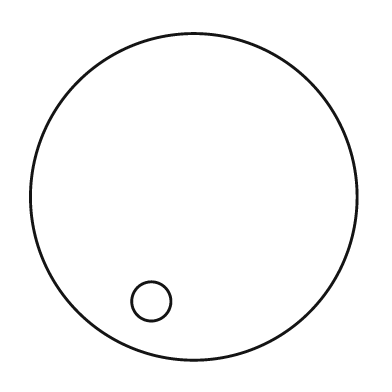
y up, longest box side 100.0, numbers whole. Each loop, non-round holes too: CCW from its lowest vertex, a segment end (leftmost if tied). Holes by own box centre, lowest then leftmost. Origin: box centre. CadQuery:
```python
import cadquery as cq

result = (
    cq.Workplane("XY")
    .moveTo(0.0, 0.0)
    .circle(50.0)
    .moveTo(-13.0, -32.0)
    .circle(6.0)
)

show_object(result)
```